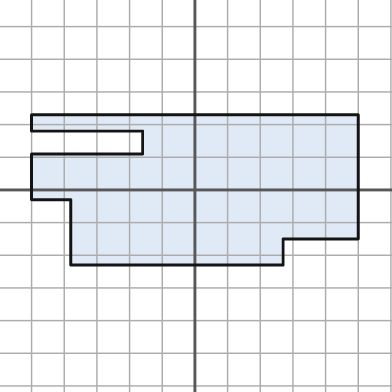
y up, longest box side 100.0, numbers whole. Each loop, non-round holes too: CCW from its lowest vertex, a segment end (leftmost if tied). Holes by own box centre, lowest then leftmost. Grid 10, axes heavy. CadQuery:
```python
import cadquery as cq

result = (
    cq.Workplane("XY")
    .moveTo(-38.0, -23.0)
    .lineTo(27.0, -23.0)
    .lineTo(27.0, -15.0)
    .lineTo(50.0, -15.0)
    .lineTo(50.0, 23.0)
    .lineTo(-50.0, 23.0)
    .lineTo(-50.0, 18.0)
    .lineTo(-16.0, 18.0)
    .lineTo(-16.0, 11.0)
    .lineTo(-50.0, 11.0)
    .lineTo(-50.0, -3.0)
    .lineTo(-38.0, -3.0)
    .close()
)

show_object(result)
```